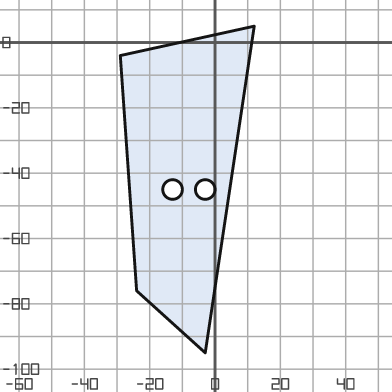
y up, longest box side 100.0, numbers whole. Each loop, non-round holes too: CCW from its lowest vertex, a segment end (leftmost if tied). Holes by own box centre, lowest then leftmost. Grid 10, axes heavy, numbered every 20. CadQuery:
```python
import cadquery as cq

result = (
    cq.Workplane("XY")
    .moveTo(-3.0, -95.0)
    .lineTo(12.0, 5.0)
    .lineTo(-29.0, -4.0)
    .lineTo(-24.0, -76.0)
    .close()
    .moveTo(-13.0, -45.0)
    .circle(3.0)
    .moveTo(-3.0, -45.0)
    .circle(3.0)
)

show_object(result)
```